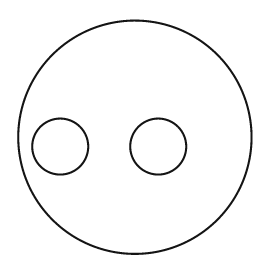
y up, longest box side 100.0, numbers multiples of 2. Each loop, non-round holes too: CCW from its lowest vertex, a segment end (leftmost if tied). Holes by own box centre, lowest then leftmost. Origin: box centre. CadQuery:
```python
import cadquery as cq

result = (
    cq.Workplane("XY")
    .moveTo(0.0, 0.0)
    .circle(50.0)
    .moveTo(-32.0, -4.0)
    .circle(12.0)
    .moveTo(10.0, -4.0)
    .circle(12.0)
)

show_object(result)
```